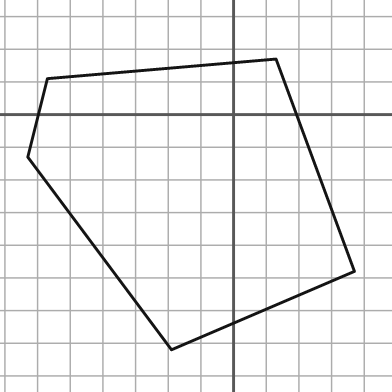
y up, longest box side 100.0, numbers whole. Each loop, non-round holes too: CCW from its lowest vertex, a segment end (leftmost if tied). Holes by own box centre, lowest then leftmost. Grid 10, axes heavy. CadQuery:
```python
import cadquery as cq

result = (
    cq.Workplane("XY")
    .moveTo(-19.0, -72.0)
    .lineTo(37.0, -48.0)
    .lineTo(13.0, 17.0)
    .lineTo(-57.0, 11.0)
    .lineTo(-63.0, -13.0)
    .close()
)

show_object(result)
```